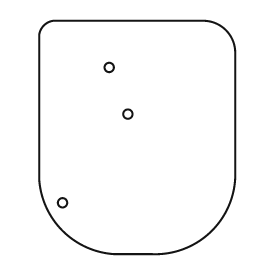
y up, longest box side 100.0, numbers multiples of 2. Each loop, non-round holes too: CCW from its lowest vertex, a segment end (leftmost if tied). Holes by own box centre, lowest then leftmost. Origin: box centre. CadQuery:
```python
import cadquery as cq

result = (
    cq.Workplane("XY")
    .moveTo(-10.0, -50.0)
    .lineTo(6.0, -50.0)
    .threePointArc((32.0, -40.0), (42.0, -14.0))
    .lineTo(42.0, 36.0)
    .threePointArc((38.0, 46.0), (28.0, 50.0))
    .lineTo(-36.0, 50.0)
    .threePointArc((-40.0, 48.0), (-42.0, 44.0))
    .lineTo(-42.0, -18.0)
    .threePointArc((-32.0, -40.0), (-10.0, -50.0))
    .close()
    .moveTo(-32.0, -28.0)
    .circle(2.0)
    .moveTo(-4.0, 10.0)
    .circle(2.0)
    .moveTo(-12.0, 30.0)
    .circle(2.0)
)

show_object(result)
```